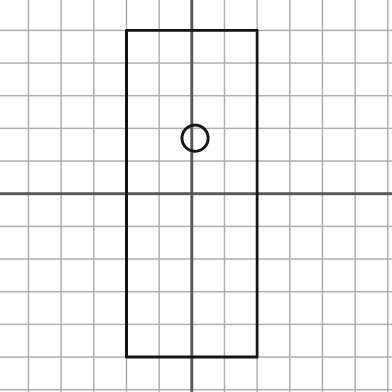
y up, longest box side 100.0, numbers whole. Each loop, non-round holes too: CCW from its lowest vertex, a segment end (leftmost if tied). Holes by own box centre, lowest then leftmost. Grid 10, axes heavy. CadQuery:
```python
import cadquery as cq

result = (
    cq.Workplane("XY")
    .moveTo(-20.0, -50.0)
    .lineTo(20.0, -50.0)
    .lineTo(20.0, 50.0)
    .lineTo(-20.0, 50.0)
    .close()
    .moveTo(1.0, 17.0)
    .circle(4.0)
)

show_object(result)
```